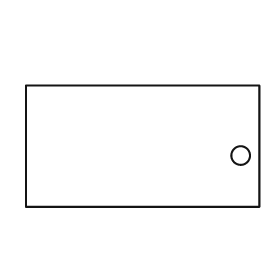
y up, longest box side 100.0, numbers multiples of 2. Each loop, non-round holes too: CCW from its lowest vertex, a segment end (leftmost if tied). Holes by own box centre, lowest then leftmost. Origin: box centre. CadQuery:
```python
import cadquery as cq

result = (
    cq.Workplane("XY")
    .moveTo(-50.0, -26.0)
    .lineTo(50.0, -26.0)
    .lineTo(50.0, 26.0)
    .lineTo(-50.0, 26.0)
    .close()
    .moveTo(42.0, -4.0)
    .circle(4.0)
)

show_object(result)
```